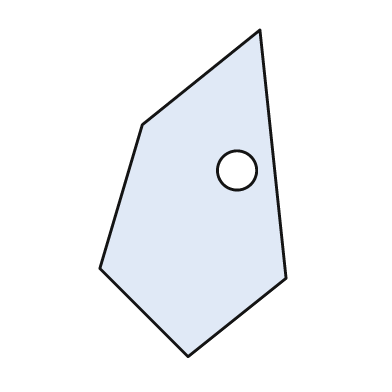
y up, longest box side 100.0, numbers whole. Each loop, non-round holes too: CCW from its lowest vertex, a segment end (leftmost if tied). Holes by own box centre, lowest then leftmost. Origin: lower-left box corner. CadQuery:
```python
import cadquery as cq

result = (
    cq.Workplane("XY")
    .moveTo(27.0, 0.0)
    .lineTo(57.0, 24.0)
    .lineTo(49.0, 100.0)
    .lineTo(13.0, 71.0)
    .lineTo(0.0, 27.0)
    .close()
    .moveTo(42.0, 57.0)
    .circle(6.0)
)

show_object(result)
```